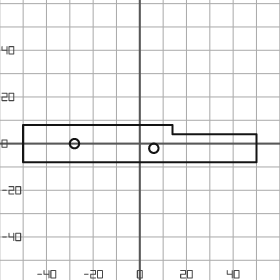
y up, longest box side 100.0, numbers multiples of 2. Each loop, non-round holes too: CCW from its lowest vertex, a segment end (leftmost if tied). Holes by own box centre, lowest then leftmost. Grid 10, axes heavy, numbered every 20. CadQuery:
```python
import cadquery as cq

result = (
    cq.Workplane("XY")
    .moveTo(-50.0, -8.0)
    .lineTo(50.0, -8.0)
    .lineTo(50.0, 4.0)
    .lineTo(14.0, 4.0)
    .lineTo(14.0, 8.0)
    .lineTo(-50.0, 8.0)
    .close()
    .moveTo(6.0, -2.0)
    .circle(2.0)
    .moveTo(-28.0, 0.0)
    .circle(2.0)
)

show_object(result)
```